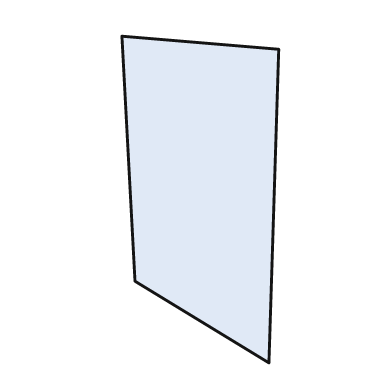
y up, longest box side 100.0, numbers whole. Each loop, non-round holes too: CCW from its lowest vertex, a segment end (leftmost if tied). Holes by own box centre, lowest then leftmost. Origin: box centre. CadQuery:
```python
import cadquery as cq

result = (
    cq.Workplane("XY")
    .moveTo(21.0, -50.0)
    .lineTo(24.0, 46.0)
    .lineTo(-24.0, 50.0)
    .lineTo(-20.0, -25.0)
    .close()
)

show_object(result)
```